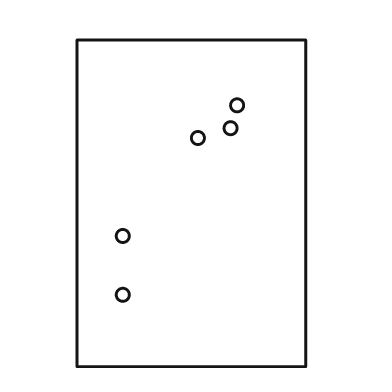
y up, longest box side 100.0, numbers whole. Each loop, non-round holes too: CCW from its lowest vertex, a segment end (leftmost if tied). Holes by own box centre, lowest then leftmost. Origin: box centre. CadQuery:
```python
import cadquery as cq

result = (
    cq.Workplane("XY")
    .moveTo(-35.0, -50.0)
    .lineTo(35.0, -50.0)
    .lineTo(35.0, 50.0)
    .lineTo(-35.0, 50.0)
    .close()
    .moveTo(-21.0, -28.0)
    .circle(2.0)
    .moveTo(-21.0, -10.0)
    .circle(2.0)
    .moveTo(2.0, 20.0)
    .circle(2.0)
    .moveTo(12.0, 23.0)
    .circle(2.0)
    .moveTo(14.0, 30.0)
    .circle(2.0)
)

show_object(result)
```